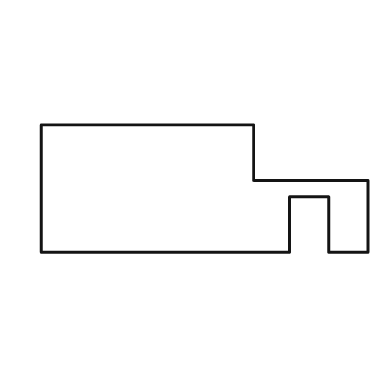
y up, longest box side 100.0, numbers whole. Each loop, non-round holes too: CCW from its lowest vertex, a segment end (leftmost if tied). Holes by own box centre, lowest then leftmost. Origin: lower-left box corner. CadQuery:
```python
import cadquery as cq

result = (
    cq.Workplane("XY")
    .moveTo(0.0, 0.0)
    .lineTo(76.0, 0.0)
    .lineTo(76.0, 17.0)
    .lineTo(88.0, 17.0)
    .lineTo(88.0, 0.0)
    .lineTo(100.0, 0.0)
    .lineTo(100.0, 22.0)
    .lineTo(65.0, 22.0)
    .lineTo(65.0, 39.0)
    .lineTo(0.0, 39.0)
    .close()
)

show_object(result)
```